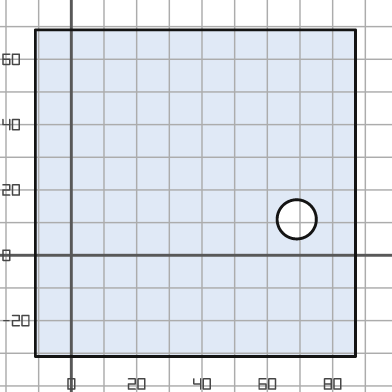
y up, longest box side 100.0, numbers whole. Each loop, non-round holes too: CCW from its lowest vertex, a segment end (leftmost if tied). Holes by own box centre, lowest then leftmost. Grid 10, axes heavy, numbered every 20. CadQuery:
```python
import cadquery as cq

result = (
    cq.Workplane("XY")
    .moveTo(-11.0, -31.0)
    .lineTo(87.0, -31.0)
    .lineTo(87.0, 69.0)
    .lineTo(-11.0, 69.0)
    .close()
    .moveTo(69.0, 11.0)
    .circle(6.0)
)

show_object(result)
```